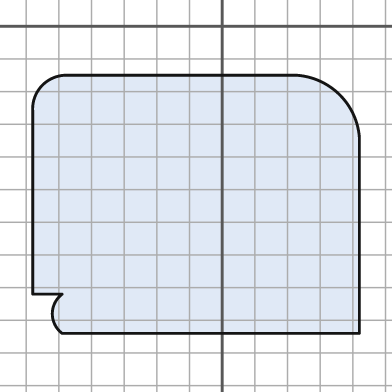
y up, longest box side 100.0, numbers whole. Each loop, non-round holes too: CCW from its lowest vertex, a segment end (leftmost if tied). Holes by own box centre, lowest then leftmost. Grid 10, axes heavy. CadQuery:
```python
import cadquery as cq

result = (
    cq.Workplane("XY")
    .moveTo(-49.0, -94.0)
    .lineTo(42.0, -94.0)
    .lineTo(42.0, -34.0)
    .threePointArc((36.0, -21.0), (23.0, -15.0))
    .lineTo(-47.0, -15.0)
    .threePointArc((-55.0, -18.0), (-58.0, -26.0))
    .lineTo(-58.0, -82.0)
    .lineTo(-49.0, -82.0)
    .threePointArc((-52.0, -88.0), (-49.0, -94.0))
    .close()
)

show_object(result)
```